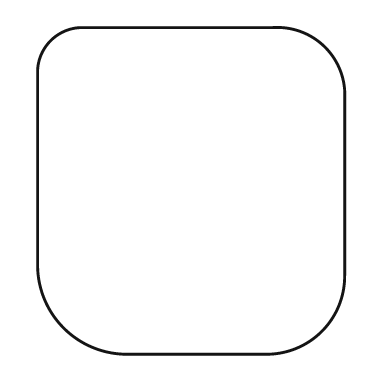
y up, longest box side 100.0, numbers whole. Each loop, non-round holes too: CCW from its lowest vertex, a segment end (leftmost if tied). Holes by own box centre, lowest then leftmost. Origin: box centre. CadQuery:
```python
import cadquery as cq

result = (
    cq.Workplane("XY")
    .moveTo(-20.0, -50.0)
    .lineTo(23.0, -50.0)
    .threePointArc((40.0, -43.0), (47.0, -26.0))
    .lineTo(47.0, 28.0)
    .threePointArc((41.0, 44.0), (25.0, 50.0))
    .lineTo(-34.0, 50.0)
    .threePointArc((-43.0, 46.0), (-47.0, 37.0))
    .lineTo(-47.0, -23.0)
    .threePointArc((-39.0, -42.0), (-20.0, -50.0))
    .close()
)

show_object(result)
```